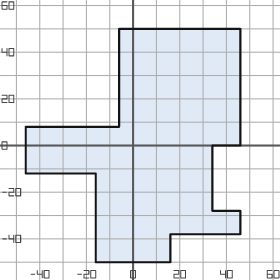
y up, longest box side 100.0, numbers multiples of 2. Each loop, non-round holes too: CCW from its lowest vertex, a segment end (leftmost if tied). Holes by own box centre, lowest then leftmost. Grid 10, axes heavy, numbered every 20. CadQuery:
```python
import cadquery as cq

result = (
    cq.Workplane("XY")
    .moveTo(-16.0, -50.0)
    .lineTo(16.0, -50.0)
    .lineTo(16.0, -38.0)
    .lineTo(46.0, -38.0)
    .lineTo(46.0, -28.0)
    .lineTo(34.0, -28.0)
    .lineTo(34.0, 0.0)
    .lineTo(46.0, 0.0)
    .lineTo(46.0, 50.0)
    .lineTo(-6.0, 50.0)
    .lineTo(-6.0, 8.0)
    .lineTo(-46.0, 8.0)
    .lineTo(-46.0, -12.0)
    .lineTo(-16.0, -12.0)
    .close()
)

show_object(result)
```